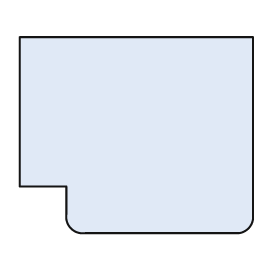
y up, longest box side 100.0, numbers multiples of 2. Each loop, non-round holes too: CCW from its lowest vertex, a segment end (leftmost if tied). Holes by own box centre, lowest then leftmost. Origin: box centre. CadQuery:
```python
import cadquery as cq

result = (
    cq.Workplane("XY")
    .moveTo(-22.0, -42.0)
    .lineTo(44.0, -42.0)
    .threePointArc((48.0, -40.0), (50.0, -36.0))
    .lineTo(50.0, 42.0)
    .lineTo(-50.0, 42.0)
    .lineTo(-50.0, -22.0)
    .lineTo(-30.0, -22.0)
    .lineTo(-30.0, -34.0)
    .threePointArc((-28.0, -40.0), (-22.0, -42.0))
    .close()
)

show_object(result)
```